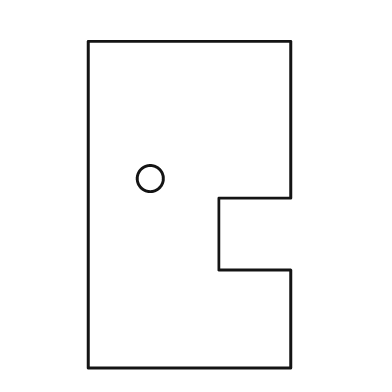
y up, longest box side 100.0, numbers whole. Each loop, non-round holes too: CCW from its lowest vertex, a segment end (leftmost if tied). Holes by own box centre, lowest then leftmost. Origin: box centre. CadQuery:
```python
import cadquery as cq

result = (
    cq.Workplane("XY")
    .moveTo(-31.0, -50.0)
    .lineTo(31.0, -50.0)
    .lineTo(31.0, -20.0)
    .lineTo(9.0, -20.0)
    .lineTo(9.0, 2.0)
    .lineTo(31.0, 2.0)
    .lineTo(31.0, 50.0)
    .lineTo(-31.0, 50.0)
    .close()
    .moveTo(-12.0, 8.0)
    .circle(4.0)
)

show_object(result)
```